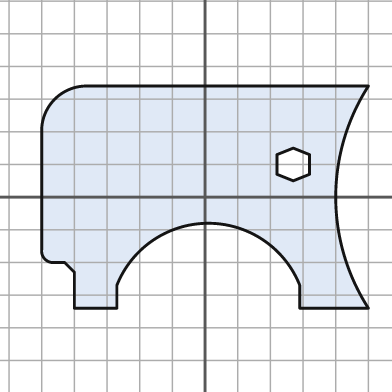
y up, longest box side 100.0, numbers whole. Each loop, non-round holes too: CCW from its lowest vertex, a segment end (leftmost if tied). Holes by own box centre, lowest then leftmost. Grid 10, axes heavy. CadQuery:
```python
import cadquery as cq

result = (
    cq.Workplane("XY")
    .moveTo(-40.0, -34.0)
    .lineTo(-27.0, -34.0)
    .lineTo(-27.0, -27.0)
    .threePointArc((1.0, -8.0), (29.0, -27.0))
    .lineTo(29.0, -34.0)
    .lineTo(50.0, -34.0)
    .threePointArc((40.0, 0.0), (50.0, 34.0))
    .lineTo(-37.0, 34.0)
    .threePointArc((-46.0, 30.0), (-50.0, 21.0))
    .lineTo(-50.0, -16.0)
    .threePointArc((-49.0, -19.0), (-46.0, -20.0))
    .lineTo(-43.0, -20.0)
    .lineTo(-40.0, -23.0)
    .close()
    .moveTo(27.0, 5.0)
    .lineTo(32.0, 7.0)
    .lineTo(32.0, 13.0)
    .lineTo(27.0, 15.0)
    .lineTo(22.0, 13.0)
    .lineTo(22.0, 7.0)
    .close()
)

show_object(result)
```